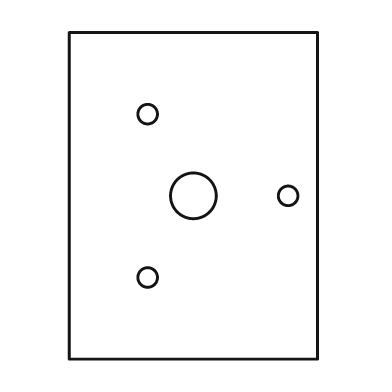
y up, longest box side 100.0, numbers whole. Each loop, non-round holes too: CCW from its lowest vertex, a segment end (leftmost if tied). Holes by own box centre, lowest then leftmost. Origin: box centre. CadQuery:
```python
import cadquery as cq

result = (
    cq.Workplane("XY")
    .moveTo(-38.0, -50.0)
    .lineTo(38.0, -50.0)
    .lineTo(38.0, 50.0)
    .lineTo(-38.0, 50.0)
    .close()
    .moveTo(-14.0, -25.0)
    .circle(3.0)
    .moveTo(0.0, 0.0)
    .circle(7.0)
    .moveTo(29.0, 0.0)
    .circle(3.0)
    .moveTo(-14.0, 25.0)
    .circle(3.0)
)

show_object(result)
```